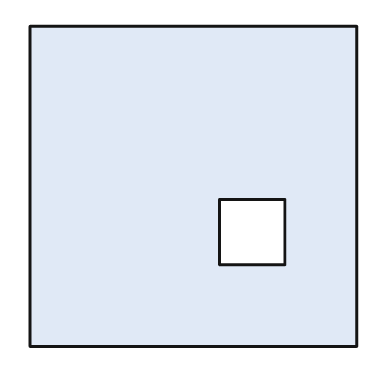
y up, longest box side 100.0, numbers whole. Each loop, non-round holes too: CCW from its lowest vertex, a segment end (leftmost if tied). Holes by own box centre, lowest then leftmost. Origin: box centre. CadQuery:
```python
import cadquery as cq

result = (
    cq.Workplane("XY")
    .moveTo(-50.0, -49.0)
    .lineTo(50.0, -49.0)
    .lineTo(50.0, 49.0)
    .lineTo(-50.0, 49.0)
    .close()
    .moveTo(8.0, -24.0)
    .lineTo(28.0, -24.0)
    .lineTo(28.0, -4.0)
    .lineTo(8.0, -4.0)
    .close()
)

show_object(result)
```